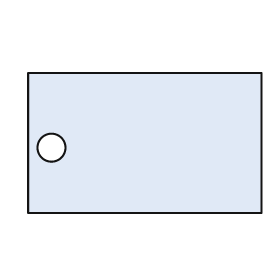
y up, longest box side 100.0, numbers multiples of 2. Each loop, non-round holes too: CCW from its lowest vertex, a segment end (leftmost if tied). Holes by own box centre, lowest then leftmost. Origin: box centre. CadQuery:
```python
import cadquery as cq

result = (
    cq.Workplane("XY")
    .moveTo(-50.0, -30.0)
    .lineTo(50.0, -30.0)
    .lineTo(50.0, 30.0)
    .lineTo(-50.0, 30.0)
    .close()
    .moveTo(-40.0, -2.0)
    .circle(6.0)
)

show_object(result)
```